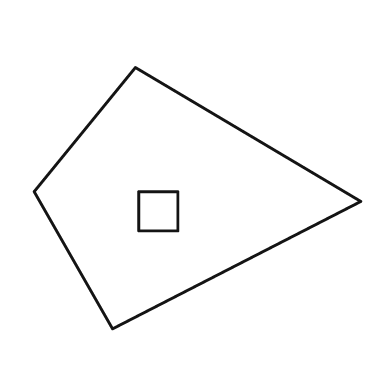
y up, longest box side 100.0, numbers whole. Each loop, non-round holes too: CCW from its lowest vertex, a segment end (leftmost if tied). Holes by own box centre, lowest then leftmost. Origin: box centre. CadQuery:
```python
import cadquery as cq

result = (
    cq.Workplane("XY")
    .moveTo(-26.0, -40.0)
    .lineTo(50.0, -1.0)
    .lineTo(-19.0, 40.0)
    .lineTo(-50.0, 2.0)
    .close()
    .moveTo(-18.0, -10.0)
    .lineTo(-6.0, -10.0)
    .lineTo(-6.0, 2.0)
    .lineTo(-18.0, 2.0)
    .close()
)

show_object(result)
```